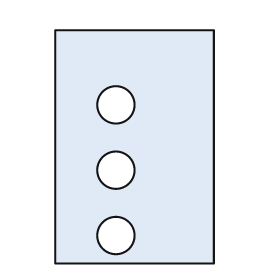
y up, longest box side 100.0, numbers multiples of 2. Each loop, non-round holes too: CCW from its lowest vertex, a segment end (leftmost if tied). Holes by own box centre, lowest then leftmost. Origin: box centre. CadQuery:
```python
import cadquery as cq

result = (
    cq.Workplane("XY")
    .moveTo(-34.0, -50.0)
    .lineTo(34.0, -50.0)
    .lineTo(34.0, 50.0)
    .lineTo(-34.0, 50.0)
    .close()
    .moveTo(-8.0, -38.0)
    .circle(8.0)
    .moveTo(-8.0, -10.0)
    .circle(8.0)
    .moveTo(-8.0, 18.0)
    .circle(8.0)
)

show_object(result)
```